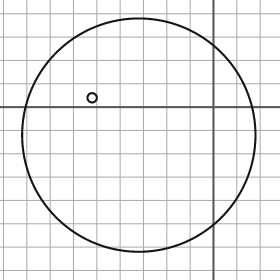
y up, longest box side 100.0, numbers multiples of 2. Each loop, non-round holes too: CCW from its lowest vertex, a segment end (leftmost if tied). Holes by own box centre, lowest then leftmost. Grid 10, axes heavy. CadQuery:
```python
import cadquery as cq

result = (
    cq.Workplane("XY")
    .moveTo(-32.0, -12.0)
    .circle(50.0)
    .moveTo(-52.0, 4.0)
    .circle(2.0)
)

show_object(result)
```